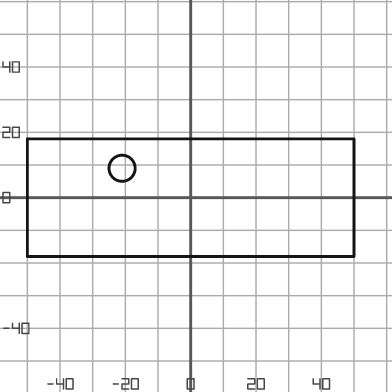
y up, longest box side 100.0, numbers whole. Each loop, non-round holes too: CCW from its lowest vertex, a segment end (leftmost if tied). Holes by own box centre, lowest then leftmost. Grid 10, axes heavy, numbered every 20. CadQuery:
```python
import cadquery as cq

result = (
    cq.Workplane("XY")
    .moveTo(-50.0, -18.0)
    .lineTo(50.0, -18.0)
    .lineTo(50.0, 18.0)
    .lineTo(-50.0, 18.0)
    .close()
    .moveTo(-21.0, 9.0)
    .circle(4.0)
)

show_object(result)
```